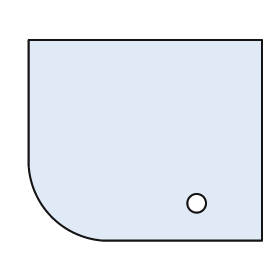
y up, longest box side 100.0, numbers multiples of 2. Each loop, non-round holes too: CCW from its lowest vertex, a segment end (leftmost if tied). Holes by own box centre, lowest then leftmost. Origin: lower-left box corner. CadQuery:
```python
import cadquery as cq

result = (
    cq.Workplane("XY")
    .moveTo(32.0, 0.0)
    .lineTo(100.0, 0.0)
    .lineTo(100.0, 86.0)
    .lineTo(0.0, 86.0)
    .lineTo(0.0, 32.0)
    .threePointArc((10.0, 10.0), (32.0, 0.0))
    .close()
    .moveTo(72.0, 16.0)
    .circle(4.0)
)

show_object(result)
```